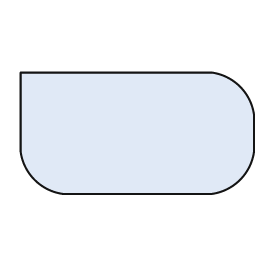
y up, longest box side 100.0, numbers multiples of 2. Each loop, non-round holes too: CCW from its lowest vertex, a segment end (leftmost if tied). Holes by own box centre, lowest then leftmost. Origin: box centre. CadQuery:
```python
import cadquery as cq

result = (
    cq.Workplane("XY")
    .moveTo(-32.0, -26.0)
    .lineTo(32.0, -26.0)
    .threePointArc((44.0, -20.0), (50.0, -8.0))
    .lineTo(50.0, 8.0)
    .threePointArc((44.0, 20.0), (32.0, 26.0))
    .lineTo(-50.0, 26.0)
    .lineTo(-50.0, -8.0)
    .threePointArc((-44.0, -20.0), (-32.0, -26.0))
    .close()
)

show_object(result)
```